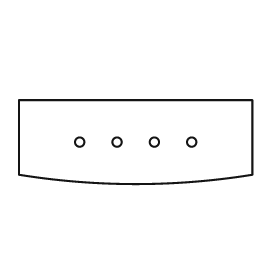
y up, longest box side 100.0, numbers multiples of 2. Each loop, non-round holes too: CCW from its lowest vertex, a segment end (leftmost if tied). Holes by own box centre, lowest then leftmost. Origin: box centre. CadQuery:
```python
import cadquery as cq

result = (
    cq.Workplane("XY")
    .moveTo(-50.0, -14.0)
    .threePointArc((0.0, -18.0), (50.0, -14.0))
    .lineTo(50.0, 18.0)
    .lineTo(-50.0, 18.0)
    .close()
    .moveTo(-24.0, 0.0)
    .circle(2.0)
    .moveTo(-8.0, 0.0)
    .circle(2.0)
    .moveTo(8.0, 0.0)
    .circle(2.0)
    .moveTo(24.0, 0.0)
    .circle(2.0)
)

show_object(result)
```